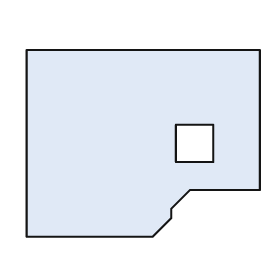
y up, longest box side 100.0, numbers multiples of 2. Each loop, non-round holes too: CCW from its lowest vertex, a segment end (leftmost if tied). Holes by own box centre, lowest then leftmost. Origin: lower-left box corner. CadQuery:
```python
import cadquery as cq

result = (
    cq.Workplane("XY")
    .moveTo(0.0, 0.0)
    .lineTo(54.0, 0.0)
    .lineTo(62.0, 8.0)
    .lineTo(62.0, 12.0)
    .lineTo(70.0, 20.0)
    .lineTo(100.0, 20.0)
    .lineTo(100.0, 80.0)
    .lineTo(0.0, 80.0)
    .close()
    .moveTo(64.0, 32.0)
    .lineTo(80.0, 32.0)
    .lineTo(80.0, 48.0)
    .lineTo(64.0, 48.0)
    .close()
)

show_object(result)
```